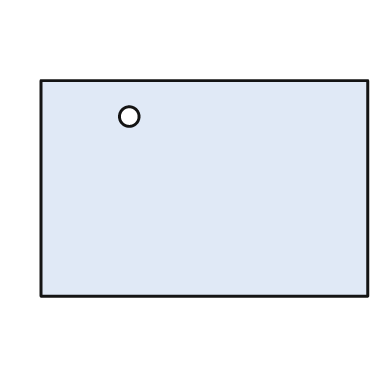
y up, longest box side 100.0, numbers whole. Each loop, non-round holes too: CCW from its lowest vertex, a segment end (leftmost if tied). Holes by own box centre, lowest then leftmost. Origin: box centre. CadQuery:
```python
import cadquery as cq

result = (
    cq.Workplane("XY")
    .moveTo(-50.0, -33.0)
    .lineTo(50.0, -33.0)
    .lineTo(50.0, 33.0)
    .lineTo(-50.0, 33.0)
    .close()
    .moveTo(-23.0, 22.0)
    .circle(3.0)
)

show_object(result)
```